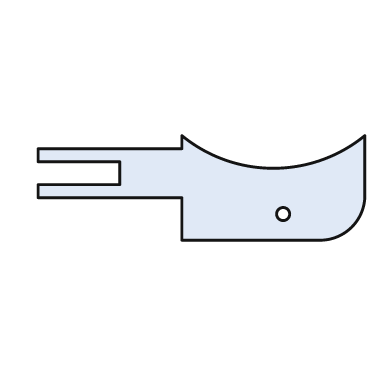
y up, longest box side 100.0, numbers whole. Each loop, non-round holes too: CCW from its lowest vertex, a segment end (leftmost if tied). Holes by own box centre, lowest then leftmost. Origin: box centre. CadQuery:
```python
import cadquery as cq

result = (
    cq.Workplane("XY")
    .moveTo(-6.0, -16.0)
    .lineTo(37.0, -16.0)
    .threePointArc((46.0, -12.0), (50.0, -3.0))
    .lineTo(50.0, 16.0)
    .threePointArc((22.0, 6.0), (-6.0, 16.0))
    .lineTo(-6.0, 12.0)
    .lineTo(-50.0, 12.0)
    .lineTo(-50.0, 8.0)
    .lineTo(-25.0, 8.0)
    .lineTo(-25.0, 1.0)
    .lineTo(-50.0, 1.0)
    .lineTo(-50.0, -3.0)
    .lineTo(-6.0, -3.0)
    .close()
    .moveTo(25.0, -8.0)
    .circle(2.0)
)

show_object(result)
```